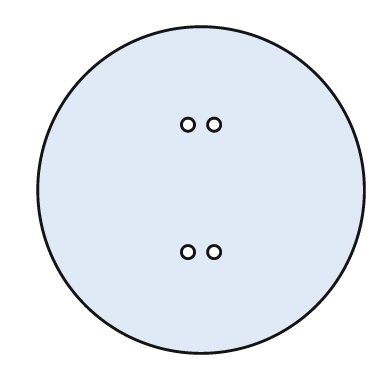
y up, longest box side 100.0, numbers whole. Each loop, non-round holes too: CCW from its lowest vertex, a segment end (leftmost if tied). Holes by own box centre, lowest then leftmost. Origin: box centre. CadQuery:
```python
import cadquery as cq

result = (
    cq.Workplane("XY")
    .moveTo(0.0, 0.0)
    .circle(50.0)
    .moveTo(-4.0, -19.0)
    .circle(2.0)
    .moveTo(4.0, -19.0)
    .circle(2.0)
    .moveTo(-4.0, 20.0)
    .circle(2.0)
    .moveTo(4.0, 20.0)
    .circle(2.0)
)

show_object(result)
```